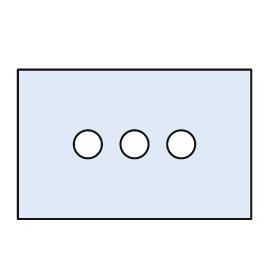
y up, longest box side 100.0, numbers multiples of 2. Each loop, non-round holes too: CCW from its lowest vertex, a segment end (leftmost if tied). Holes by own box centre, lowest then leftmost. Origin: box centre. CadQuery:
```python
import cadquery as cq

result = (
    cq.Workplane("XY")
    .moveTo(-50.0, -32.0)
    .lineTo(50.0, -32.0)
    .lineTo(50.0, 32.0)
    .lineTo(-50.0, 32.0)
    .close()
    .moveTo(-20.0, 0.0)
    .circle(6.0)
    .moveTo(0.0, 0.0)
    .circle(6.0)
    .moveTo(20.0, 0.0)
    .circle(6.0)
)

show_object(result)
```